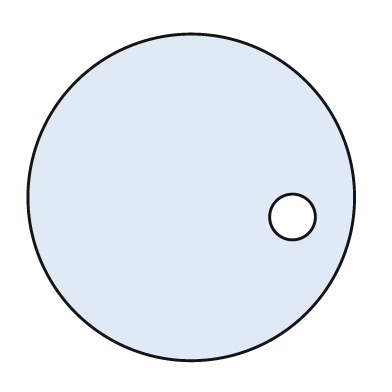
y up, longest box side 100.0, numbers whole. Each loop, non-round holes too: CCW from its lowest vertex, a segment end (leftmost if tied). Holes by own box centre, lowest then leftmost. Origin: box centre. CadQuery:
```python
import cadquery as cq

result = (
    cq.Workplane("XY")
    .moveTo(0.0, 0.0)
    .circle(50.0)
    .moveTo(31.0, -6.0)
    .circle(7.0)
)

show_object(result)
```